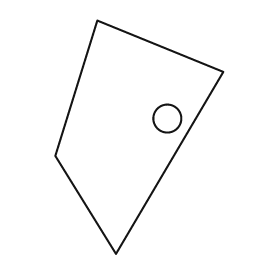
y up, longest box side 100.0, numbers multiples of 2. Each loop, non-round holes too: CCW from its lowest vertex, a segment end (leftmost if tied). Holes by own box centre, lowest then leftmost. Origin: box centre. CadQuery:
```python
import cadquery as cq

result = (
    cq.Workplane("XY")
    .moveTo(-10.0, -50.0)
    .lineTo(36.0, 28.0)
    .lineTo(-18.0, 50.0)
    .lineTo(-36.0, -8.0)
    .close()
    .moveTo(12.0, 8.0)
    .circle(6.0)
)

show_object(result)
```